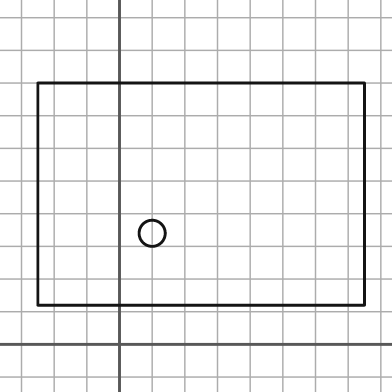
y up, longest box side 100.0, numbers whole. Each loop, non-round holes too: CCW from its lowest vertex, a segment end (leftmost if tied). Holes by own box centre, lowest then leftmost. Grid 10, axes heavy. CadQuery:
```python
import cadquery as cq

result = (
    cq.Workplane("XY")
    .moveTo(-25.0, 12.0)
    .lineTo(75.0, 12.0)
    .lineTo(75.0, 80.0)
    .lineTo(-25.0, 80.0)
    .close()
    .moveTo(10.0, 34.0)
    .circle(4.0)
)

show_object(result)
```